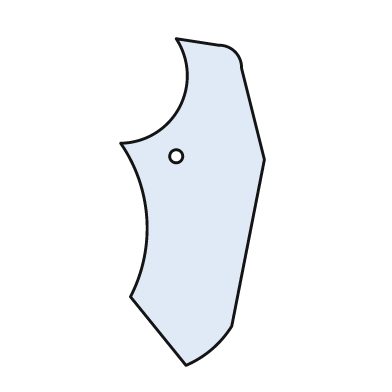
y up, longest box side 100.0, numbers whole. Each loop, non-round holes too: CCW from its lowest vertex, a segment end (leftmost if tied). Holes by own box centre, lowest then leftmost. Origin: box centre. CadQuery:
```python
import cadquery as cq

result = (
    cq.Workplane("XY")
    .moveTo(-2.0, -50.0)
    .threePointArc((6.0, -45.0), (12.0, -38.0))
    .lineTo(22.0, 13.0)
    .lineTo(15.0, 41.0)
    .threePointArc((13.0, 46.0), (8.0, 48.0))
    .lineTo(-5.0, 50.0)
    .threePointArc((-4.0, 29.0), (-22.0, 18.0))
    .threePointArc((-14.0, -5.0), (-19.0, -29.0))
    .close()
    .moveTo(-5.0, 14.0)
    .circle(2.0)
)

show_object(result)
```